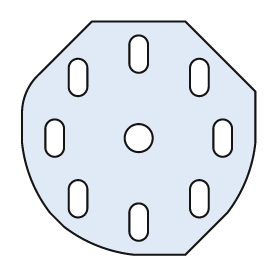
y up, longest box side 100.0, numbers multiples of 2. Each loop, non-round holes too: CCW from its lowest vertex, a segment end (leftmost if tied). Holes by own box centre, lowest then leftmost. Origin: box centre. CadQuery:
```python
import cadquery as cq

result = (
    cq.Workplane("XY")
    .moveTo(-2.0, -50.0)
    .lineTo(20.0, -50.0)
    .lineTo(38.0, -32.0)
    .threePointArc((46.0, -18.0), (50.0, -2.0))
    .lineTo(50.0, 20.0)
    .lineTo(20.0, 50.0)
    .lineTo(-20.0, 50.0)
    .lineTo(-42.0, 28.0)
    .threePointArc((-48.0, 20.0), (-50.0, 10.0))
    .lineTo(-50.0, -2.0)
    .threePointArc((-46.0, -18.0), (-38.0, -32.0))
    .lineTo(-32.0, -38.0)
    .threePointArc((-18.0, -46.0), (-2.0, -50.0))
    .close()
    .moveTo(-4.0, -40.0)
    .threePointArc((0.0, -44.0), (4.0, -40.0))
    .lineTo(4.0, -32.0)
    .threePointArc((0.0, -28.0), (-4.0, -32.0))
    .close()
    .moveTo(-30.0, -30.0)
    .threePointArc((-26.0, -34.0), (-22.0, -30.0))
    .lineTo(-22.0, -22.0)
    .threePointArc((-26.0, -18.0), (-30.0, -22.0))
    .close()
    .moveTo(22.0, -30.0)
    .threePointArc((26.0, -34.0), (30.0, -30.0))
    .lineTo(30.0, -22.0)
    .threePointArc((26.0, -18.0), (22.0, -22.0))
    .close()
    .moveTo(-40.0, -4.0)
    .threePointArc((-36.0, -8.0), (-32.0, -4.0))
    .lineTo(-32.0, 4.0)
    .threePointArc((-36.0, 8.0), (-40.0, 4.0))
    .close()
    .moveTo(0.0, 0.0)
    .circle(6.0)
    .moveTo(32.0, -4.0)
    .threePointArc((36.0, -8.0), (40.0, -4.0))
    .lineTo(40.0, 4.0)
    .threePointArc((36.0, 8.0), (32.0, 4.0))
    .close()
    .moveTo(-30.0, 22.0)
    .threePointArc((-26.0, 18.0), (-22.0, 22.0))
    .lineTo(-22.0, 30.0)
    .threePointArc((-26.0, 34.0), (-30.0, 30.0))
    .close()
    .moveTo(22.0, 22.0)
    .threePointArc((26.0, 18.0), (30.0, 22.0))
    .lineTo(30.0, 30.0)
    .threePointArc((26.0, 34.0), (22.0, 30.0))
    .close()
    .moveTo(-4.0, 32.0)
    .threePointArc((0.0, 28.0), (4.0, 32.0))
    .lineTo(4.0, 40.0)
    .threePointArc((0.0, 44.0), (-4.0, 40.0))
    .close()
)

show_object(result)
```